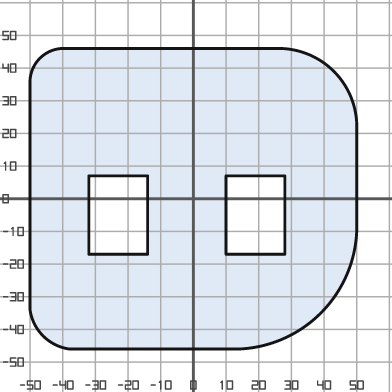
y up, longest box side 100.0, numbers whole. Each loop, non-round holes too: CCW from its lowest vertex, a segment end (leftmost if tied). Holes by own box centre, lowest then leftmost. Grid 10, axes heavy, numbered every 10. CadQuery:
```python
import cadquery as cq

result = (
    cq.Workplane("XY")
    .moveTo(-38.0, -46.0)
    .lineTo(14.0, -46.0)
    .threePointArc((39.0, -35.0), (50.0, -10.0))
    .lineTo(50.0, 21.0)
    .threePointArc((43.0, 39.0), (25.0, 46.0))
    .lineTo(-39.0, 46.0)
    .threePointArc((-47.0, 43.0), (-50.0, 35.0))
    .lineTo(-50.0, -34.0)
    .threePointArc((-46.0, -42.0), (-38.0, -46.0))
    .close()
    .moveTo(-32.0, -17.0)
    .lineTo(-14.0, -17.0)
    .lineTo(-14.0, 7.0)
    .lineTo(-32.0, 7.0)
    .close()
    .moveTo(10.0, -17.0)
    .lineTo(28.0, -17.0)
    .lineTo(28.0, 7.0)
    .lineTo(10.0, 7.0)
    .close()
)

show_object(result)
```